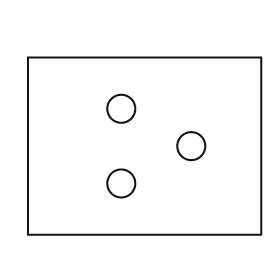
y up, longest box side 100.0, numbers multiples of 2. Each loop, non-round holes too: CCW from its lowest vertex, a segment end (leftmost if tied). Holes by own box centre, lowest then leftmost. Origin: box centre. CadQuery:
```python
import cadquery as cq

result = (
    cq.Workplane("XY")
    .moveTo(-50.0, -38.0)
    .lineTo(50.0, -38.0)
    .lineTo(50.0, 38.0)
    .lineTo(-50.0, 38.0)
    .close()
    .moveTo(-10.0, -16.0)
    .circle(6.0)
    .moveTo(20.0, 0.0)
    .circle(6.0)
    .moveTo(-10.0, 16.0)
    .circle(6.0)
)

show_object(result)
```